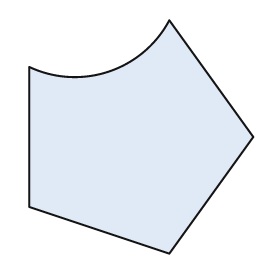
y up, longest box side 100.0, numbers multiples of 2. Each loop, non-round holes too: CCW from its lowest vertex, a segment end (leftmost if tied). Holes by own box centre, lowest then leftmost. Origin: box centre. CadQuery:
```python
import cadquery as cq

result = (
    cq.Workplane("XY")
    .moveTo(12.0, -50.0)
    .lineTo(48.0, 0.0)
    .lineTo(12.0, 50.0)
    .threePointArc((-14.0, 28.0), (-48.0, 30.0))
    .lineTo(-48.0, -30.0)
    .close()
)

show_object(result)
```